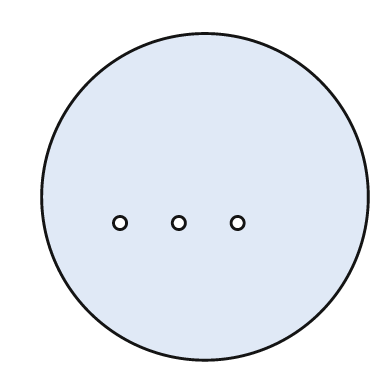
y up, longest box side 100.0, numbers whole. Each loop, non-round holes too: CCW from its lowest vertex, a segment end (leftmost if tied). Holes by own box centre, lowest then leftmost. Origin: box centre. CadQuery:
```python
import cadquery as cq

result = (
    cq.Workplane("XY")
    .moveTo(0.0, 0.0)
    .circle(50.0)
    .moveTo(-26.0, -8.0)
    .circle(2.0)
    .moveTo(-8.0, -8.0)
    .circle(2.0)
    .moveTo(10.0, -8.0)
    .circle(2.0)
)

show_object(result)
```